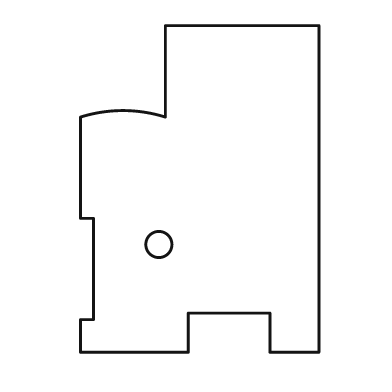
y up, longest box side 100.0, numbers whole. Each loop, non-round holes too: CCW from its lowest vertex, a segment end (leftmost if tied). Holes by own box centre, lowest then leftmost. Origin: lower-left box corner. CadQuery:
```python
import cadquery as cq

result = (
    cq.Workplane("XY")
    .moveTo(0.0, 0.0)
    .lineTo(33.0, 0.0)
    .lineTo(33.0, 12.0)
    .lineTo(58.0, 12.0)
    .lineTo(58.0, 0.0)
    .lineTo(73.0, 0.0)
    .lineTo(73.0, 100.0)
    .lineTo(26.0, 100.0)
    .lineTo(26.0, 72.0)
    .threePointArc((13.0, 74.0), (0.0, 72.0))
    .lineTo(0.0, 41.0)
    .lineTo(4.0, 41.0)
    .lineTo(4.0, 10.0)
    .lineTo(0.0, 10.0)
    .close()
    .moveTo(24.0, 33.0)
    .circle(4.0)
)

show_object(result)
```